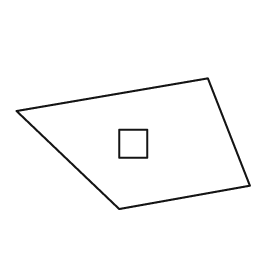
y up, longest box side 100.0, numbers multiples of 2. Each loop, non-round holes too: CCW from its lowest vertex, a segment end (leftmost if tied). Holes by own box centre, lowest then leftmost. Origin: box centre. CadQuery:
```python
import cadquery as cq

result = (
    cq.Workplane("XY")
    .moveTo(-6.0, -28.0)
    .lineTo(50.0, -18.0)
    .lineTo(32.0, 28.0)
    .lineTo(-50.0, 14.0)
    .close()
    .moveTo(-6.0, -6.0)
    .lineTo(6.0, -6.0)
    .lineTo(6.0, 6.0)
    .lineTo(-6.0, 6.0)
    .close()
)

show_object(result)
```